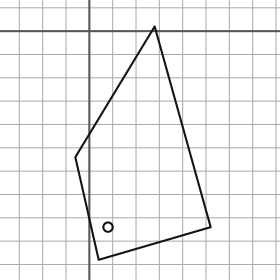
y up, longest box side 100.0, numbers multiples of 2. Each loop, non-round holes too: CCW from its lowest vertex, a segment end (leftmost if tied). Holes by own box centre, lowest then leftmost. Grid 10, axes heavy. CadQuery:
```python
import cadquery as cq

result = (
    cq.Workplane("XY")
    .moveTo(4.0, -98.0)
    .lineTo(52.0, -84.0)
    .lineTo(28.0, 2.0)
    .lineTo(-6.0, -54.0)
    .close()
    .moveTo(8.0, -84.0)
    .circle(2.0)
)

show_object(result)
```